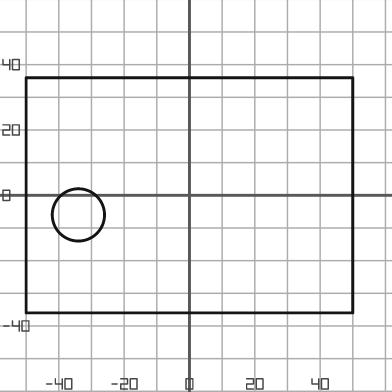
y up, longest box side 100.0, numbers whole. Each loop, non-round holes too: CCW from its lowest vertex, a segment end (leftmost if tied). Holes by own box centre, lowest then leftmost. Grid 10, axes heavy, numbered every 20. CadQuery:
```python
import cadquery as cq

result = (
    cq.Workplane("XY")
    .moveTo(-50.0, -36.0)
    .lineTo(50.0, -36.0)
    .lineTo(50.0, 36.0)
    .lineTo(-50.0, 36.0)
    .close()
    .moveTo(-34.0, -6.0)
    .circle(8.0)
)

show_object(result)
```